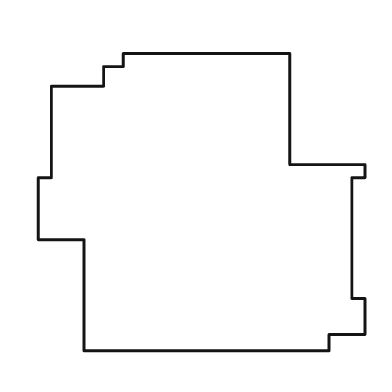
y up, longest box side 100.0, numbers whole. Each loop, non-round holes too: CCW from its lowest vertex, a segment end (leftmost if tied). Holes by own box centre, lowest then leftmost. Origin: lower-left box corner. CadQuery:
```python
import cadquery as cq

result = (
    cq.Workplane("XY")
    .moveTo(14.0, 0.0)
    .lineTo(89.0, 0.0)
    .lineTo(89.0, 5.0)
    .lineTo(100.0, 5.0)
    .lineTo(100.0, 16.0)
    .lineTo(96.0, 16.0)
    .lineTo(96.0, 53.0)
    .lineTo(100.0, 53.0)
    .lineTo(100.0, 57.0)
    .lineTo(77.0, 57.0)
    .lineTo(77.0, 91.0)
    .lineTo(26.0, 91.0)
    .lineTo(26.0, 87.0)
    .lineTo(20.0, 87.0)
    .lineTo(20.0, 81.0)
    .lineTo(4.0, 81.0)
    .lineTo(4.0, 53.0)
    .lineTo(0.0, 53.0)
    .lineTo(0.0, 34.0)
    .lineTo(14.0, 34.0)
    .close()
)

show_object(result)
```